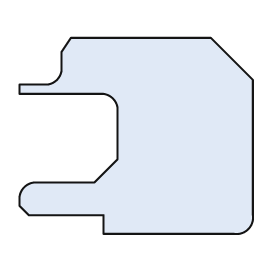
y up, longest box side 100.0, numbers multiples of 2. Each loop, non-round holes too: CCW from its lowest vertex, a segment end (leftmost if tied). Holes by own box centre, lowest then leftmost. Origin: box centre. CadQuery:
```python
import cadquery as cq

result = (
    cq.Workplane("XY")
    .moveTo(-14.0, -42.0)
    .lineTo(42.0, -42.0)
    .threePointArc((48.0, -40.0), (50.0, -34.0))
    .lineTo(50.0, 24.0)
    .lineTo(32.0, 42.0)
    .lineTo(-28.0, 42.0)
    .lineTo(-32.0, 36.0)
    .lineTo(-32.0, 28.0)
    .threePointArc((-34.0, 24.0), (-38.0, 22.0))
    .lineTo(-50.0, 22.0)
    .lineTo(-50.0, 18.0)
    .lineTo(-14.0, 18.0)
    .threePointArc((-10.0, 16.0), (-8.0, 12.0))
    .lineTo(-8.0, -10.0)
    .lineTo(-18.0, -20.0)
    .lineTo(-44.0, -20.0)
    .threePointArc((-48.0, -22.0), (-50.0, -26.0))
    .lineTo(-50.0, -30.0)
    .lineTo(-46.0, -34.0)
    .lineTo(-14.0, -34.0)
    .close()
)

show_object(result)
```